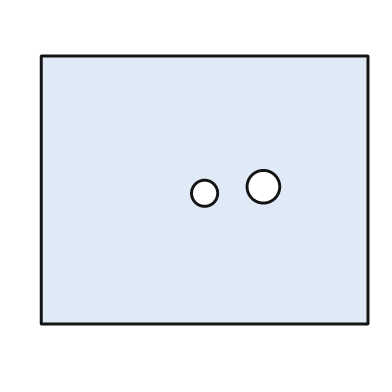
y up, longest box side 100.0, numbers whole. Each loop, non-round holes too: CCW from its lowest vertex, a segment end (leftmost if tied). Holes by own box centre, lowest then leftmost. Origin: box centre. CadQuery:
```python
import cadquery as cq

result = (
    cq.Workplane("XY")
    .moveTo(-50.0, -41.0)
    .lineTo(50.0, -41.0)
    .lineTo(50.0, 41.0)
    .lineTo(-50.0, 41.0)
    .close()
    .moveTo(0.0, -1.0)
    .circle(4.0)
    .moveTo(18.0, 1.0)
    .circle(5.0)
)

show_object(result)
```